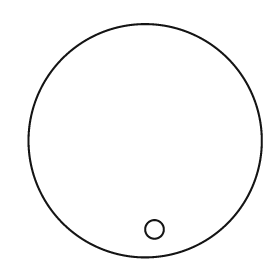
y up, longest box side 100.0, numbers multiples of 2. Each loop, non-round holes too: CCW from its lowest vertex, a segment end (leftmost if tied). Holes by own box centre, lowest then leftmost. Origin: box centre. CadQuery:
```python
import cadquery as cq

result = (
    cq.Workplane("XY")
    .moveTo(0.0, 0.0)
    .circle(50.0)
    .moveTo(4.0, -38.0)
    .circle(4.0)
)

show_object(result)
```